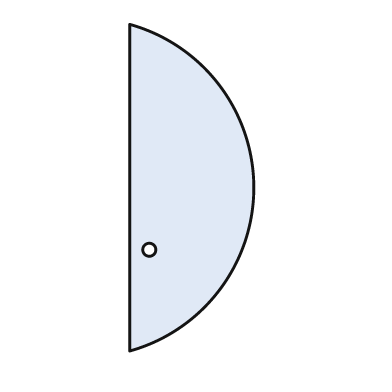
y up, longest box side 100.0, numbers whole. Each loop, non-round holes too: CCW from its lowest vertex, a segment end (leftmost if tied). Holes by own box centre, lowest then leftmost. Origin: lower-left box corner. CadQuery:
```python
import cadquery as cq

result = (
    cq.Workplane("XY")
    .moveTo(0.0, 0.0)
    .threePointArc((38.0, 50.0), (0.0, 100.0))
    .close()
    .moveTo(6.0, 31.0)
    .circle(2.0)
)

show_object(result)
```